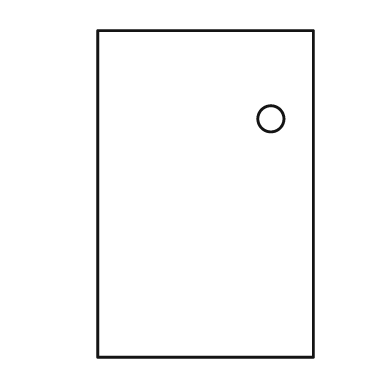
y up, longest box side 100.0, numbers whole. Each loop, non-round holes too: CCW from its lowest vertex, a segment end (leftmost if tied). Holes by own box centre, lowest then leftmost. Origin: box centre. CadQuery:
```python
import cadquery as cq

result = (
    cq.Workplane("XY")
    .moveTo(-33.0, -50.0)
    .lineTo(33.0, -50.0)
    .lineTo(33.0, 50.0)
    .lineTo(-33.0, 50.0)
    .close()
    .moveTo(20.0, 23.0)
    .circle(4.0)
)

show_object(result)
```